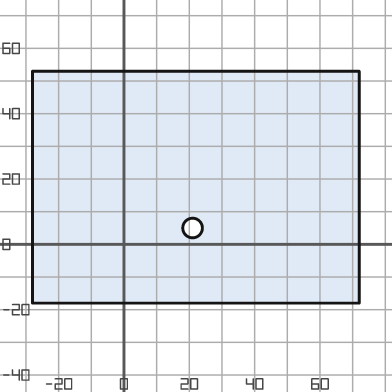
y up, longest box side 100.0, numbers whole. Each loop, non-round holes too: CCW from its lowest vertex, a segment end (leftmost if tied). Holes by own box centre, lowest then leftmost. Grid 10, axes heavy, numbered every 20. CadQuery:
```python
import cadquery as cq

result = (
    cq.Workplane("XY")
    .moveTo(-28.0, -18.0)
    .lineTo(72.0, -18.0)
    .lineTo(72.0, 53.0)
    .lineTo(-28.0, 53.0)
    .close()
    .moveTo(21.0, 5.0)
    .circle(3.0)
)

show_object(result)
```